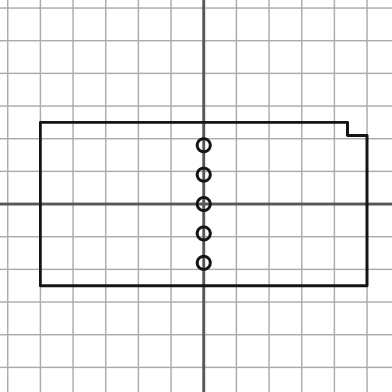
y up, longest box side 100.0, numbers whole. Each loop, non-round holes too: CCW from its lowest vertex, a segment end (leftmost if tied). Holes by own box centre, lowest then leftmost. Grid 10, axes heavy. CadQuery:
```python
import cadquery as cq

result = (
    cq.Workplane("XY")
    .moveTo(-50.0, -25.0)
    .lineTo(50.0, -25.0)
    .lineTo(50.0, 21.0)
    .lineTo(44.0, 21.0)
    .lineTo(44.0, 25.0)
    .lineTo(-50.0, 25.0)
    .close()
    .moveTo(0.0, -18.0)
    .circle(2.0)
    .moveTo(0.0, -9.0)
    .circle(2.0)
    .moveTo(0.0, 0.0)
    .circle(2.0)
    .moveTo(0.0, 9.0)
    .circle(2.0)
    .moveTo(0.0, 18.0)
    .circle(2.0)
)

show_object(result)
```